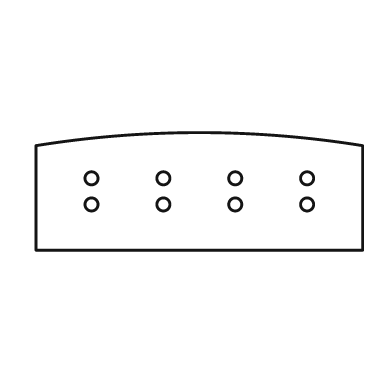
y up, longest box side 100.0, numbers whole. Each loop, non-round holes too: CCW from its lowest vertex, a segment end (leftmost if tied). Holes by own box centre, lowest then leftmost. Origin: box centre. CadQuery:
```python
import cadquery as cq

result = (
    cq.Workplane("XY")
    .moveTo(-50.0, -18.0)
    .lineTo(50.0, -18.0)
    .lineTo(50.0, 14.0)
    .threePointArc((0.0, 18.0), (-50.0, 14.0))
    .close()
    .moveTo(-33.0, -4.0)
    .circle(2.0)
    .moveTo(-11.0, -4.0)
    .circle(2.0)
    .moveTo(11.0, -4.0)
    .circle(2.0)
    .moveTo(33.0, -4.0)
    .circle(2.0)
    .moveTo(-33.0, 4.0)
    .circle(2.0)
    .moveTo(-11.0, 4.0)
    .circle(2.0)
    .moveTo(11.0, 4.0)
    .circle(2.0)
    .moveTo(33.0, 4.0)
    .circle(2.0)
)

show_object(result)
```